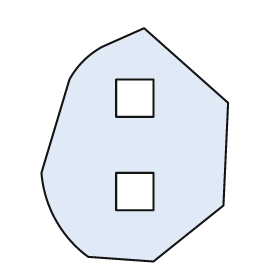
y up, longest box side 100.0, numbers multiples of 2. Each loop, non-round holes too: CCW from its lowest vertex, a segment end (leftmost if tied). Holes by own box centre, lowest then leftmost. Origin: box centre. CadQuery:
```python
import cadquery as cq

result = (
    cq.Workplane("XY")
    .moveTo(8.0, -50.0)
    .lineTo(38.0, -26.0)
    .lineTo(40.0, 18.0)
    .lineTo(4.0, 50.0)
    .lineTo(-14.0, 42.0)
    .threePointArc((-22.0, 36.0), (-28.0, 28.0))
    .lineTo(-40.0, -12.0)
    .threePointArc((-34.0, -32.0), (-20.0, -48.0))
    .close()
    .moveTo(-8.0, -28.0)
    .lineTo(8.0, -28.0)
    .lineTo(8.0, -12.0)
    .lineTo(-8.0, -12.0)
    .close()
    .moveTo(-8.0, 12.0)
    .lineTo(8.0, 12.0)
    .lineTo(8.0, 28.0)
    .lineTo(-8.0, 28.0)
    .close()
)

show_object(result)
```